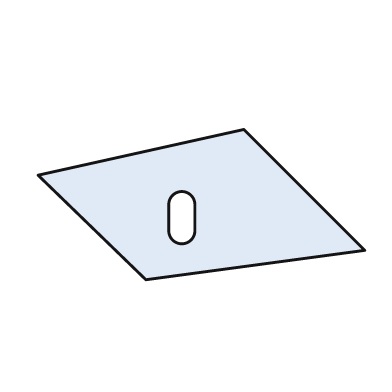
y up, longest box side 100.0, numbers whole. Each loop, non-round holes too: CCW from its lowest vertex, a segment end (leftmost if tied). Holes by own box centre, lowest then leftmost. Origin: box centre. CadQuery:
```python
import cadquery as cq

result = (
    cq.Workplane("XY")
    .moveTo(-17.0, -23.0)
    .lineTo(50.0, -14.0)
    .lineTo(13.0, 23.0)
    .lineTo(-50.0, 9.0)
    .close()
    .moveTo(-10.0, -8.0)
    .threePointArc((-6.0, -12.0), (-2.0, -8.0))
    .lineTo(-2.0, 0.0)
    .threePointArc((-6.0, 4.0), (-10.0, 0.0))
    .close()
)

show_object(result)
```